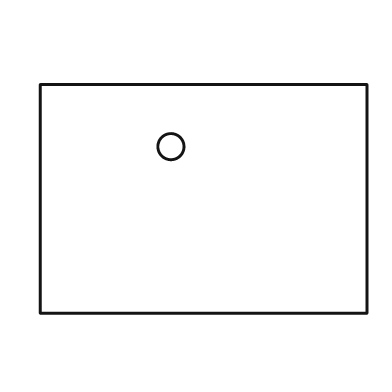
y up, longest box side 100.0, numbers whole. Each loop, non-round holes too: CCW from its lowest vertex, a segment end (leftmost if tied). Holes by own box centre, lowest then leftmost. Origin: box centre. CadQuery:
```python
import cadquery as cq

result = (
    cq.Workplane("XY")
    .moveTo(-50.0, -35.0)
    .lineTo(50.0, -35.0)
    .lineTo(50.0, 35.0)
    .lineTo(-50.0, 35.0)
    .close()
    .moveTo(-10.0, 16.0)
    .circle(4.0)
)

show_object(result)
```